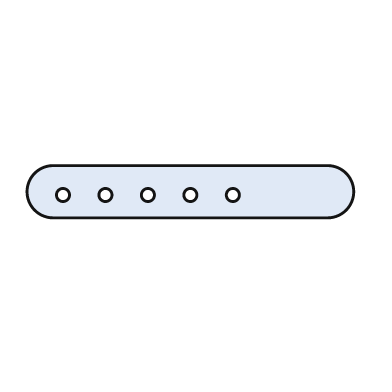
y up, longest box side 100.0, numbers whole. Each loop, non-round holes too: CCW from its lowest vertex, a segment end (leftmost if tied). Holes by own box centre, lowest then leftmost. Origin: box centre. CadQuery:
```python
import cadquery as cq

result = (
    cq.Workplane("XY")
    .moveTo(-42.0, -8.0)
    .lineTo(42.0, -8.0)
    .threePointArc((50.0, 0.0), (42.0, 8.0))
    .lineTo(-42.0, 8.0)
    .threePointArc((-50.0, 0.0), (-42.0, -8.0))
    .close()
    .moveTo(-39.0, -1.0)
    .circle(2.0)
    .moveTo(-26.0, -1.0)
    .circle(2.0)
    .moveTo(-13.0, -1.0)
    .circle(2.0)
    .moveTo(0.0, -1.0)
    .circle(2.0)
    .moveTo(13.0, -1.0)
    .circle(2.0)
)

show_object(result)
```